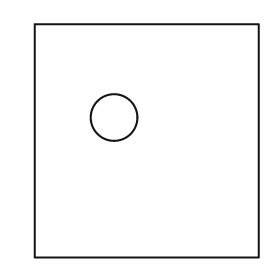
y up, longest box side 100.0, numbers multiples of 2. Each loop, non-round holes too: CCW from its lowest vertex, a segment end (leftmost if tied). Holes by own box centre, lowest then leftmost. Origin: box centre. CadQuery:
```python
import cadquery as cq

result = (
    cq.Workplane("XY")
    .moveTo(-48.0, -50.0)
    .lineTo(48.0, -50.0)
    .lineTo(48.0, 50.0)
    .lineTo(-48.0, 50.0)
    .close()
    .moveTo(-14.0, 10.0)
    .circle(10.0)
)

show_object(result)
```